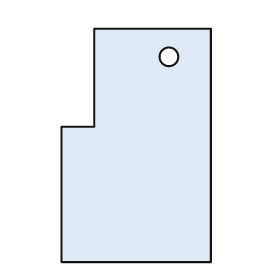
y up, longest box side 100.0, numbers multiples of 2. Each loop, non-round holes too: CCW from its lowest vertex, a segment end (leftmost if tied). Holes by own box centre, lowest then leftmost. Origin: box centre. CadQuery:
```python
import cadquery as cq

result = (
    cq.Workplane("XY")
    .moveTo(-32.0, -50.0)
    .lineTo(32.0, -50.0)
    .lineTo(32.0, 50.0)
    .lineTo(-18.0, 50.0)
    .lineTo(-18.0, 8.0)
    .lineTo(-32.0, 8.0)
    .close()
    .moveTo(14.0, 38.0)
    .circle(4.0)
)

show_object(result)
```